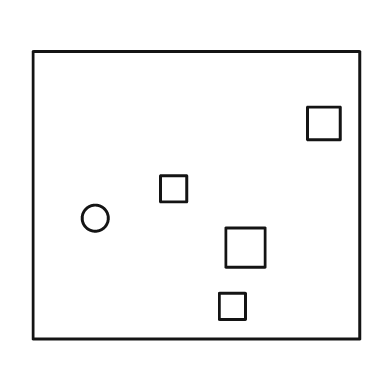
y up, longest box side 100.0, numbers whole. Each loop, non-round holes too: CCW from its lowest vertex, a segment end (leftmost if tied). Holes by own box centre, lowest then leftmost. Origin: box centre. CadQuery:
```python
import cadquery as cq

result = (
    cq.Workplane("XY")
    .moveTo(-50.0, -44.0)
    .lineTo(50.0, -44.0)
    .lineTo(50.0, 44.0)
    .lineTo(-50.0, 44.0)
    .close()
    .moveTo(7.0, -38.0)
    .lineTo(15.0, -38.0)
    .lineTo(15.0, -30.0)
    .lineTo(7.0, -30.0)
    .close()
    .moveTo(9.0, -22.0)
    .lineTo(21.0, -22.0)
    .lineTo(21.0, -10.0)
    .lineTo(9.0, -10.0)
    .close()
    .moveTo(-31.0, -7.0)
    .circle(4.0)
    .moveTo(-11.0, -2.0)
    .lineTo(-3.0, -2.0)
    .lineTo(-3.0, 6.0)
    .lineTo(-11.0, 6.0)
    .close()
    .moveTo(34.0, 17.0)
    .lineTo(44.0, 17.0)
    .lineTo(44.0, 27.0)
    .lineTo(34.0, 27.0)
    .close()
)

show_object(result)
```